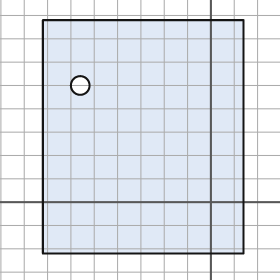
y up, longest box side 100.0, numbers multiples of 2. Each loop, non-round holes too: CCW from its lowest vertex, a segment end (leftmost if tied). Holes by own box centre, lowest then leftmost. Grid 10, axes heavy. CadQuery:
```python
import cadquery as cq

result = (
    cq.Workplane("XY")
    .moveTo(-72.0, -22.0)
    .lineTo(14.0, -22.0)
    .lineTo(14.0, 78.0)
    .lineTo(-72.0, 78.0)
    .close()
    .moveTo(-56.0, 50.0)
    .circle(4.0)
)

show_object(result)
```